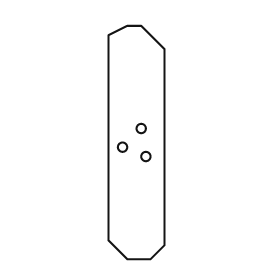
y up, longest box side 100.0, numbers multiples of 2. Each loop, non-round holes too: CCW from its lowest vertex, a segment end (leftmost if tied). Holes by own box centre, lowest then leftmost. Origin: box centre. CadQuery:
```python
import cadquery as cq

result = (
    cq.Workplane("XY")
    .moveTo(-4.0, -50.0)
    .lineTo(6.0, -50.0)
    .lineTo(12.0, -44.0)
    .lineTo(12.0, 40.0)
    .lineTo(2.0, 50.0)
    .lineTo(-4.0, 50.0)
    .lineTo(-12.0, 46.0)
    .lineTo(-12.0, -42.0)
    .close()
    .moveTo(4.0, -6.0)
    .circle(2.0)
    .moveTo(-6.0, -2.0)
    .circle(2.0)
    .moveTo(2.0, 6.0)
    .circle(2.0)
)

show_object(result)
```